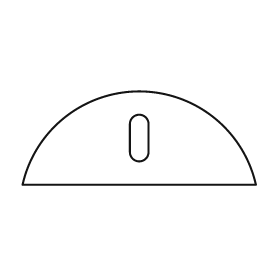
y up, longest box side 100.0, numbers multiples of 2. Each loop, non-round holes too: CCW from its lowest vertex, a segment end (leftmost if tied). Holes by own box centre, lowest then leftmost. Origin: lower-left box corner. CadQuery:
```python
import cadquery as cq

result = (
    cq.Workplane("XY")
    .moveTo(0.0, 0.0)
    .lineTo(100.0, 0.0)
    .threePointArc((50.0, 40.0), (0.0, 0.0))
    .close()
    .moveTo(46.0, 14.0)
    .threePointArc((50.0, 10.0), (54.0, 14.0))
    .lineTo(54.0, 26.0)
    .threePointArc((50.0, 30.0), (46.0, 26.0))
    .close()
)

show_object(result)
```